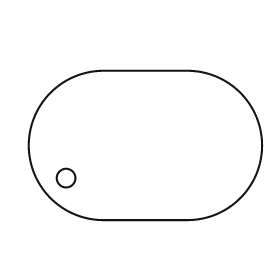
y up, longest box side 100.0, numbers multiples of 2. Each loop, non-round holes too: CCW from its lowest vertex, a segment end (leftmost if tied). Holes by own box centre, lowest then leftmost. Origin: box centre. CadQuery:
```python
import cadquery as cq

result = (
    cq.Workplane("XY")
    .moveTo(-18.0, -32.0)
    .lineTo(18.0, -32.0)
    .threePointArc((50.0, 0.0), (18.0, 32.0))
    .lineTo(-18.0, 32.0)
    .threePointArc((-50.0, 0.0), (-18.0, -32.0))
    .close()
    .moveTo(-34.0, -14.0)
    .circle(4.0)
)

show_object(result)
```